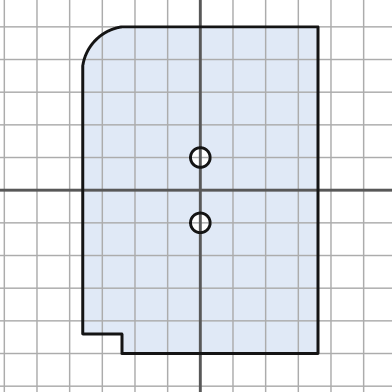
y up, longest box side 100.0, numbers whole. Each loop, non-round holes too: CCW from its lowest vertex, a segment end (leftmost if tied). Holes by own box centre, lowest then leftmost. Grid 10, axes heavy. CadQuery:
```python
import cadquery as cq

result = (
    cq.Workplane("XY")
    .moveTo(-24.0, -50.0)
    .lineTo(36.0, -50.0)
    .lineTo(36.0, 50.0)
    .lineTo(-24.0, 50.0)
    .threePointArc((-32.0, 46.0), (-36.0, 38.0))
    .lineTo(-36.0, -44.0)
    .lineTo(-24.0, -44.0)
    .close()
    .moveTo(0.0, -10.0)
    .circle(3.0)
    .moveTo(0.0, 10.0)
    .circle(3.0)
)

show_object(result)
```